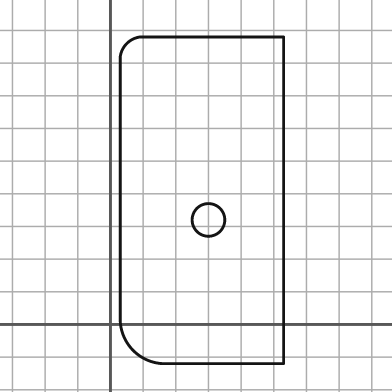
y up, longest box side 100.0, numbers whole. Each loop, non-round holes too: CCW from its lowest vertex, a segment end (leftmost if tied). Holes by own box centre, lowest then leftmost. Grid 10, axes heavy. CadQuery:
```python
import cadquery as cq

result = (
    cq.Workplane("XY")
    .moveTo(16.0, -12.0)
    .lineTo(53.0, -12.0)
    .lineTo(53.0, 88.0)
    .lineTo(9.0, 88.0)
    .threePointArc((5.0, 86.0), (3.0, 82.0))
    .lineTo(3.0, 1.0)
    .threePointArc((7.0, -8.0), (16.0, -12.0))
    .close()
    .moveTo(30.0, 32.0)
    .circle(5.0)
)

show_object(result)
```